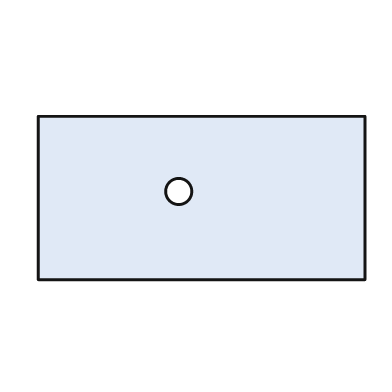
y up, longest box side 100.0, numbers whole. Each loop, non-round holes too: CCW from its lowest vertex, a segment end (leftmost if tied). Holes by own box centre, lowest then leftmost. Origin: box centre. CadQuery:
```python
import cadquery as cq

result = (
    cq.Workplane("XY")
    .moveTo(-50.0, -25.0)
    .lineTo(50.0, -25.0)
    .lineTo(50.0, 25.0)
    .lineTo(-50.0, 25.0)
    .close()
    .moveTo(-7.0, 2.0)
    .circle(4.0)
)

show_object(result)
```